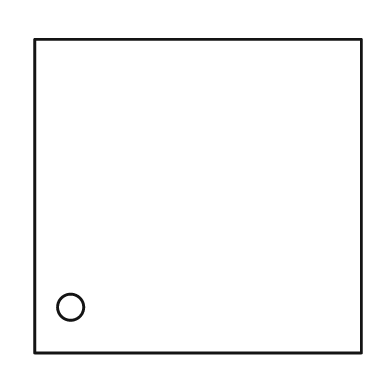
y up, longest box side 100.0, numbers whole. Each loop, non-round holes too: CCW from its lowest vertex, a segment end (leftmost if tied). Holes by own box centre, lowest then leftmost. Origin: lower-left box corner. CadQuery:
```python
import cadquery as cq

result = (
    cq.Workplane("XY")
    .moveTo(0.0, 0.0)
    .lineTo(100.0, 0.0)
    .lineTo(100.0, 96.0)
    .lineTo(0.0, 96.0)
    .close()
    .moveTo(11.0, 14.0)
    .circle(4.0)
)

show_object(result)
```